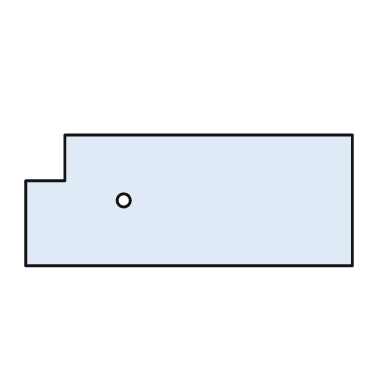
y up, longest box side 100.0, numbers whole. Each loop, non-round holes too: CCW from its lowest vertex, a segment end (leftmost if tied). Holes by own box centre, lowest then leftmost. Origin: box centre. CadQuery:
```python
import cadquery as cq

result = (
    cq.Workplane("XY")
    .moveTo(-50.0, -20.0)
    .lineTo(50.0, -20.0)
    .lineTo(50.0, 20.0)
    .lineTo(-38.0, 20.0)
    .lineTo(-38.0, 6.0)
    .lineTo(-50.0, 6.0)
    .close()
    .moveTo(-20.0, 0.0)
    .circle(2.0)
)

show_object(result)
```